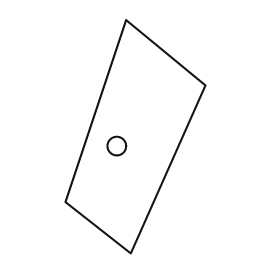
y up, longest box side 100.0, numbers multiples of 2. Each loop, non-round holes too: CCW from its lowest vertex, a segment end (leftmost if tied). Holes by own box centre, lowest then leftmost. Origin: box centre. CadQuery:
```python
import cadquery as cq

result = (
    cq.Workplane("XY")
    .moveTo(-2.0, -50.0)
    .lineTo(30.0, 22.0)
    .lineTo(-4.0, 50.0)
    .lineTo(-30.0, -28.0)
    .close()
    .moveTo(-8.0, -4.0)
    .circle(4.0)
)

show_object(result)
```